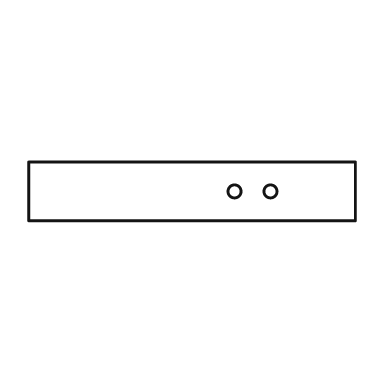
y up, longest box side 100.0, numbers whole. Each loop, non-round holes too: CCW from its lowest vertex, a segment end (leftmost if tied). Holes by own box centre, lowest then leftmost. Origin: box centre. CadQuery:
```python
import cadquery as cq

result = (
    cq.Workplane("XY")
    .moveTo(-50.0, -9.0)
    .lineTo(50.0, -9.0)
    .lineTo(50.0, 9.0)
    .lineTo(-50.0, 9.0)
    .close()
    .moveTo(13.0, 0.0)
    .circle(2.0)
    .moveTo(24.0, 0.0)
    .circle(2.0)
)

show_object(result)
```